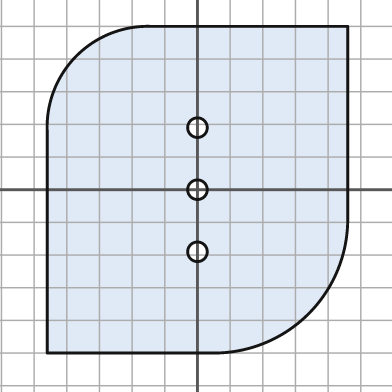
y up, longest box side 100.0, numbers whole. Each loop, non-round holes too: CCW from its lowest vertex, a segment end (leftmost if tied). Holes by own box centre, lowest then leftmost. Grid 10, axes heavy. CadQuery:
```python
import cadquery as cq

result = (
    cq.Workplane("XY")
    .moveTo(-46.0, -50.0)
    .lineTo(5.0, -50.0)
    .threePointArc((34.0, -38.0), (46.0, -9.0))
    .lineTo(46.0, 50.0)
    .lineTo(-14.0, 50.0)
    .threePointArc((-37.0, 41.0), (-46.0, 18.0))
    .close()
    .moveTo(0.0, -19.0)
    .circle(3.0)
    .moveTo(0.0, 0.0)
    .circle(3.0)
    .moveTo(0.0, 19.0)
    .circle(3.0)
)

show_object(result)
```